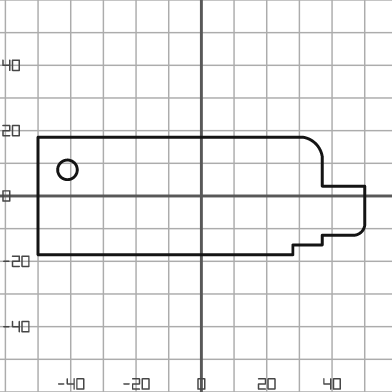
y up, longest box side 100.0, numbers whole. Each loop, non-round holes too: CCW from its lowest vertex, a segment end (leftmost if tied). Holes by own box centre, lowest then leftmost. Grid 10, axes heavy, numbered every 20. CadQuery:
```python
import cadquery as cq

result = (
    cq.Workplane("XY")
    .moveTo(-50.0, -18.0)
    .lineTo(28.0, -18.0)
    .lineTo(28.0, -15.0)
    .lineTo(37.0, -15.0)
    .lineTo(37.0, -12.0)
    .lineTo(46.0, -12.0)
    .threePointArc((49.0, -11.0), (50.0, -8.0))
    .lineTo(50.0, 3.0)
    .lineTo(37.0, 3.0)
    .lineTo(37.0, 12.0)
    .threePointArc((35.0, 16.0), (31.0, 18.0))
    .lineTo(-50.0, 18.0)
    .close()
    .moveTo(-41.0, 8.0)
    .circle(3.0)
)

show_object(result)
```